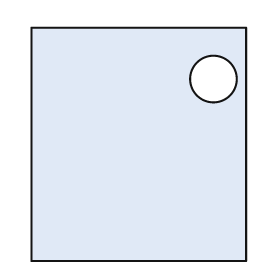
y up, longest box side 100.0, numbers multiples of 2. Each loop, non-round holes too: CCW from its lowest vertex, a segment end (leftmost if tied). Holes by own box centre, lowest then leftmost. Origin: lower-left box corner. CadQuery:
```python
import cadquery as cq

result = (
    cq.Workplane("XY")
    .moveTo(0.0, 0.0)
    .lineTo(92.0, 0.0)
    .lineTo(92.0, 100.0)
    .lineTo(0.0, 100.0)
    .close()
    .moveTo(78.0, 78.0)
    .circle(10.0)
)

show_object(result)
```